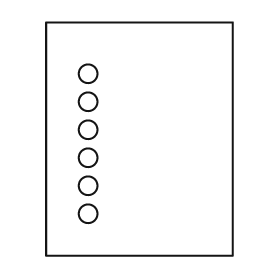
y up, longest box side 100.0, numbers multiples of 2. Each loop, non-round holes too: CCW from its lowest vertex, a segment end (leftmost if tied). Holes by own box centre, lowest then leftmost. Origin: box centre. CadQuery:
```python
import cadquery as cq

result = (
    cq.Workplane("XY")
    .moveTo(-40.0, -50.0)
    .lineTo(40.0, -50.0)
    .lineTo(40.0, 50.0)
    .lineTo(-40.0, 50.0)
    .close()
    .moveTo(-22.0, -32.0)
    .circle(4.0)
    .moveTo(-22.0, -20.0)
    .circle(4.0)
    .moveTo(-22.0, -8.0)
    .circle(4.0)
    .moveTo(-22.0, 4.0)
    .circle(4.0)
    .moveTo(-22.0, 16.0)
    .circle(4.0)
    .moveTo(-22.0, 28.0)
    .circle(4.0)
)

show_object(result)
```